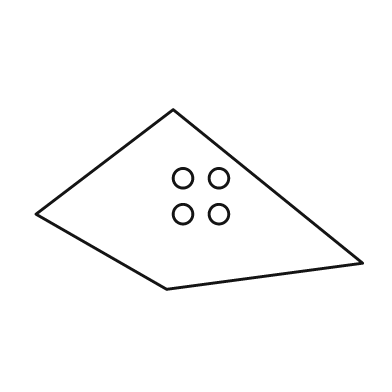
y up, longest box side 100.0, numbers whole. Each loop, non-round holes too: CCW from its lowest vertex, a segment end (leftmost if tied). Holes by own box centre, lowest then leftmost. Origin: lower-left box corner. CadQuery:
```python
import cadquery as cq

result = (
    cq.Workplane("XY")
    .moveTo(40.0, 0.0)
    .lineTo(100.0, 8.0)
    .lineTo(42.0, 55.0)
    .lineTo(0.0, 23.0)
    .close()
    .moveTo(45.0, 23.0)
    .circle(3.0)
    .moveTo(56.0, 23.0)
    .circle(3.0)
    .moveTo(45.0, 34.0)
    .circle(3.0)
    .moveTo(56.0, 34.0)
    .circle(3.0)
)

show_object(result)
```